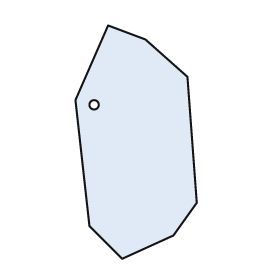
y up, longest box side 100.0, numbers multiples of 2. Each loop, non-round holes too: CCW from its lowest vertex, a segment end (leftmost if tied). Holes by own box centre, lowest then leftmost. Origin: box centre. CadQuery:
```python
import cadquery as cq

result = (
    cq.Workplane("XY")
    .moveTo(-6.0, -50.0)
    .lineTo(16.0, -40.0)
    .lineTo(26.0, -26.0)
    .lineTo(22.0, 28.0)
    .lineTo(4.0, 44.0)
    .lineTo(-12.0, 50.0)
    .lineTo(-26.0, 18.0)
    .lineTo(-20.0, -36.0)
    .close()
    .moveTo(-18.0, 16.0)
    .circle(2.0)
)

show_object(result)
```